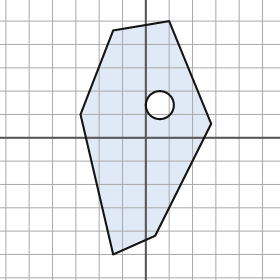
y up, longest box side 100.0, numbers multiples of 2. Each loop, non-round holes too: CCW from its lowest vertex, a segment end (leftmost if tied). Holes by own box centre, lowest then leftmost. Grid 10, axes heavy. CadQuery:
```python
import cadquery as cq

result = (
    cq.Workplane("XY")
    .moveTo(-14.0, -50.0)
    .lineTo(4.0, -42.0)
    .lineTo(28.0, 6.0)
    .lineTo(10.0, 50.0)
    .lineTo(-14.0, 46.0)
    .lineTo(-28.0, 10.0)
    .close()
    .moveTo(6.0, 14.0)
    .circle(6.0)
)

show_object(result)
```